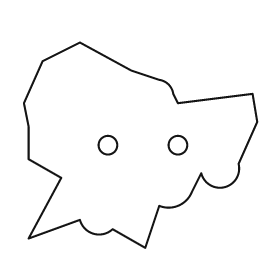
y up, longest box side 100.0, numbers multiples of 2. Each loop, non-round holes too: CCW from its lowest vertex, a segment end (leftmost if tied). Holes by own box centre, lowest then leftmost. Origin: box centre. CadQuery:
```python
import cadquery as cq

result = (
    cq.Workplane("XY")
    .moveTo(2.0, -44.0)
    .lineTo(8.0, -26.0)
    .threePointArc((16.0, -26.0), (22.0, -20.0))
    .lineTo(26.0, -12.0)
    .threePointArc((36.0, -18.0), (42.0, -8.0))
    .lineTo(50.0, 10.0)
    .lineTo(48.0, 22.0)
    .lineTo(16.0, 18.0)
    .lineTo(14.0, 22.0)
    .threePointArc((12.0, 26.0), (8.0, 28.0))
    .lineTo(-4.0, 32.0)
    .lineTo(-26.0, 44.0)
    .lineTo(-42.0, 36.0)
    .lineTo(-50.0, 18.0)
    .lineTo(-48.0, 8.0)
    .lineTo(-48.0, -6.0)
    .lineTo(-34.0, -14.0)
    .lineTo(-48.0, -40.0)
    .lineTo(-26.0, -32.0)
    .threePointArc((-20.0, -38.0), (-12.0, -36.0))
    .close()
    .moveTo(-14.0, 0.0)
    .circle(4.0)
    .moveTo(16.0, 0.0)
    .circle(4.0)
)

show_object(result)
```